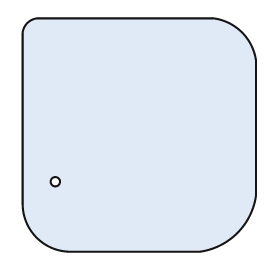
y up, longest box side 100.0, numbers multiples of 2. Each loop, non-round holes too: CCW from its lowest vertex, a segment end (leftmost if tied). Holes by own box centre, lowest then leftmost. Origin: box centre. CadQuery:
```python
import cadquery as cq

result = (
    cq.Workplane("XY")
    .moveTo(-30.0, -50.0)
    .lineTo(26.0, -50.0)
    .threePointArc((42.0, -42.0), (50.0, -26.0))
    .lineTo(50.0, 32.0)
    .threePointArc((44.0, 44.0), (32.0, 50.0))
    .lineTo(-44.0, 50.0)
    .threePointArc((-48.0, 48.0), (-50.0, 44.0))
    .lineTo(-50.0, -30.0)
    .threePointArc((-44.0, -44.0), (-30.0, -50.0))
    .close()
    .moveTo(-36.0, -20.0)
    .circle(2.0)
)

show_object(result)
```